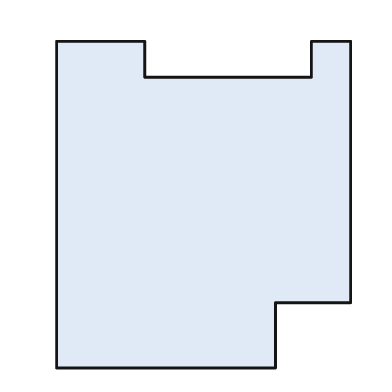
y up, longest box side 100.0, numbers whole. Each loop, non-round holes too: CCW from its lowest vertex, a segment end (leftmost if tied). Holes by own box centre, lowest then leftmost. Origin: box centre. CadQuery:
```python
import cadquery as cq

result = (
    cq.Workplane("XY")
    .moveTo(-45.0, -50.0)
    .lineTo(22.0, -50.0)
    .lineTo(22.0, -30.0)
    .lineTo(45.0, -30.0)
    .lineTo(45.0, 50.0)
    .lineTo(33.0, 50.0)
    .lineTo(33.0, 39.0)
    .lineTo(-18.0, 39.0)
    .lineTo(-18.0, 50.0)
    .lineTo(-45.0, 50.0)
    .close()
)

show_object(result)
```